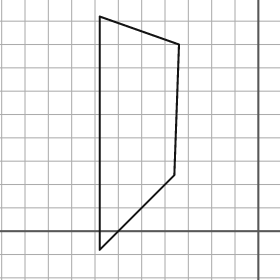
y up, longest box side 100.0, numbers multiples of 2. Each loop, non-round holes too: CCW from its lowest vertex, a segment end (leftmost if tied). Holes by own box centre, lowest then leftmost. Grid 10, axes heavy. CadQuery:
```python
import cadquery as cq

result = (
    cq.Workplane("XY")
    .moveTo(-68.0, -8.0)
    .lineTo(-36.0, 24.0)
    .lineTo(-34.0, 80.0)
    .lineTo(-68.0, 92.0)
    .close()
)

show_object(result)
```